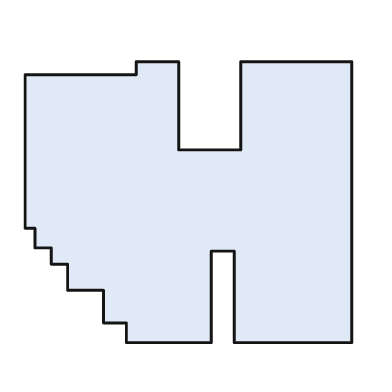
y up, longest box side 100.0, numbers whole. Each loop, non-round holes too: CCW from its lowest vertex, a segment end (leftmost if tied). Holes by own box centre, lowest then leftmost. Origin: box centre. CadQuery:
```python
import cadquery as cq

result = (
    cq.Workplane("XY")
    .moveTo(-19.0, -43.0)
    .lineTo(7.0, -43.0)
    .lineTo(7.0, -15.0)
    .lineTo(14.0, -15.0)
    .lineTo(14.0, -43.0)
    .lineTo(50.0, -43.0)
    .lineTo(50.0, 43.0)
    .lineTo(16.0, 43.0)
    .lineTo(16.0, 16.0)
    .lineTo(-3.0, 16.0)
    .lineTo(-3.0, 43.0)
    .lineTo(-16.0, 43.0)
    .lineTo(-16.0, 39.0)
    .lineTo(-50.0, 39.0)
    .lineTo(-50.0, -8.0)
    .lineTo(-47.0, -8.0)
    .lineTo(-47.0, -14.0)
    .lineTo(-42.0, -14.0)
    .lineTo(-42.0, -19.0)
    .lineTo(-37.0, -19.0)
    .lineTo(-37.0, -27.0)
    .lineTo(-26.0, -27.0)
    .lineTo(-26.0, -37.0)
    .lineTo(-19.0, -37.0)
    .close()
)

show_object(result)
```